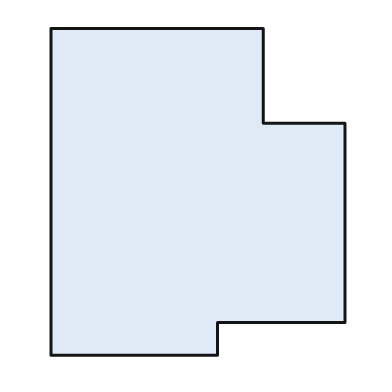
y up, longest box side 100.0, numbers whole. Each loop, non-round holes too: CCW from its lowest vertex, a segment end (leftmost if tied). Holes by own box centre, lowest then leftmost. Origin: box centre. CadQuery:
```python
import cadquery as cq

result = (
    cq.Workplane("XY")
    .moveTo(-45.0, -50.0)
    .lineTo(6.0, -50.0)
    .lineTo(6.0, -40.0)
    .lineTo(45.0, -40.0)
    .lineTo(45.0, 21.0)
    .lineTo(20.0, 21.0)
    .lineTo(20.0, 50.0)
    .lineTo(-45.0, 50.0)
    .close()
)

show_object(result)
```